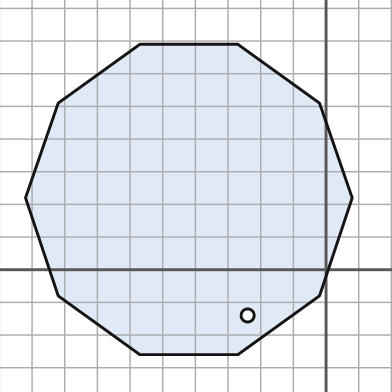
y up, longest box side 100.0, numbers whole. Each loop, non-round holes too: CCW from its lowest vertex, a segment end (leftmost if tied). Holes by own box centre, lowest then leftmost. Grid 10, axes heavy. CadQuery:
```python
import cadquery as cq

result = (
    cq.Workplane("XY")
    .moveTo(-57.0, -26.0)
    .lineTo(-27.0, -26.0)
    .lineTo(-2.0, -8.0)
    .lineTo(8.0, 22.0)
    .lineTo(-2.0, 51.0)
    .lineTo(-27.0, 69.0)
    .lineTo(-57.0, 69.0)
    .lineTo(-82.0, 51.0)
    .lineTo(-92.0, 22.0)
    .lineTo(-82.0, -8.0)
    .close()
    .moveTo(-24.0, -14.0)
    .circle(2.0)
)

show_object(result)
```